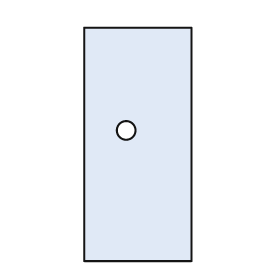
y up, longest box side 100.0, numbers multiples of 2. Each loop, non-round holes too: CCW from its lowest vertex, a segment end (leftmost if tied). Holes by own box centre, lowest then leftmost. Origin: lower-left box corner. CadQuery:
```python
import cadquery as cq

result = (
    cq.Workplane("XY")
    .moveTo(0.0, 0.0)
    .lineTo(46.0, 0.0)
    .lineTo(46.0, 100.0)
    .lineTo(0.0, 100.0)
    .close()
    .moveTo(18.0, 56.0)
    .circle(4.0)
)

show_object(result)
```